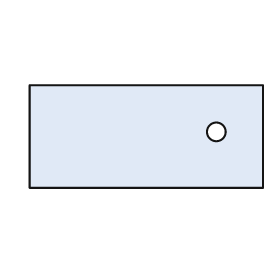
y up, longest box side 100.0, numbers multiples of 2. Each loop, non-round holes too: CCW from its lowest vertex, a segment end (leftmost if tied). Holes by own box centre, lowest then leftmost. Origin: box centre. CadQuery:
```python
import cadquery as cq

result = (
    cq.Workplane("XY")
    .moveTo(-50.0, -22.0)
    .lineTo(50.0, -22.0)
    .lineTo(50.0, 22.0)
    .lineTo(-50.0, 22.0)
    .close()
    .moveTo(30.0, 2.0)
    .circle(4.0)
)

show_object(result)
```